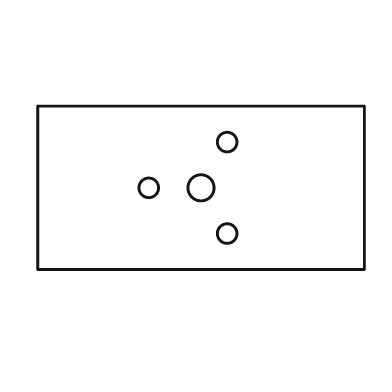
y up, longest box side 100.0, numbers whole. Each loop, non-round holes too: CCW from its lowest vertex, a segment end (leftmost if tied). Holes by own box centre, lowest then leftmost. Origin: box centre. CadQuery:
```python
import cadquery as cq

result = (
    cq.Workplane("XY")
    .moveTo(-50.0, -25.0)
    .lineTo(50.0, -25.0)
    .lineTo(50.0, 25.0)
    .lineTo(-50.0, 25.0)
    .close()
    .moveTo(8.0, -14.0)
    .circle(3.0)
    .moveTo(-16.0, 0.0)
    .circle(3.0)
    .moveTo(0.0, 0.0)
    .circle(4.0)
    .moveTo(8.0, 14.0)
    .circle(3.0)
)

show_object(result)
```